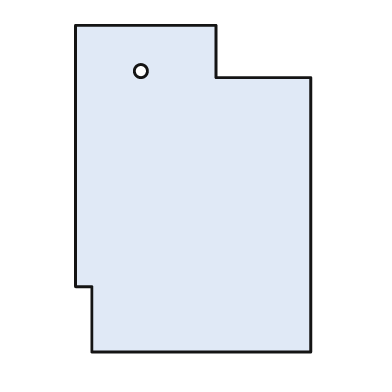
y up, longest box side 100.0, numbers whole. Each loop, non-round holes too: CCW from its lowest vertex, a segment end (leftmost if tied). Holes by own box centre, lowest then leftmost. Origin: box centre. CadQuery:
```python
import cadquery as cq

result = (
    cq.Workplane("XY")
    .moveTo(-31.0, -50.0)
    .lineTo(36.0, -50.0)
    .lineTo(36.0, 34.0)
    .lineTo(7.0, 34.0)
    .lineTo(7.0, 50.0)
    .lineTo(-36.0, 50.0)
    .lineTo(-36.0, -30.0)
    .lineTo(-31.0, -30.0)
    .close()
    .moveTo(-16.0, 36.0)
    .circle(2.0)
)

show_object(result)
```